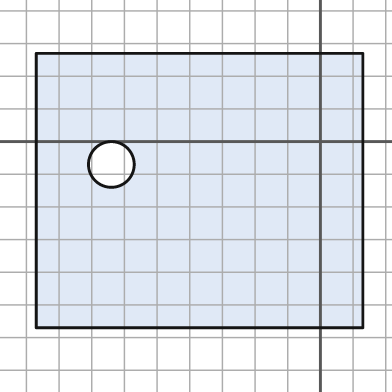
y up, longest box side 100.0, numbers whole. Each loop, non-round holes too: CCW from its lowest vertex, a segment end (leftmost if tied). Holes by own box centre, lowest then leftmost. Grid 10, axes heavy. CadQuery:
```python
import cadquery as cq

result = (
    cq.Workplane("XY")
    .moveTo(-87.0, -57.0)
    .lineTo(13.0, -57.0)
    .lineTo(13.0, 27.0)
    .lineTo(-87.0, 27.0)
    .close()
    .moveTo(-64.0, -7.0)
    .circle(7.0)
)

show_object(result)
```